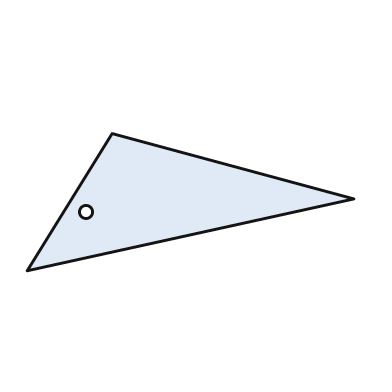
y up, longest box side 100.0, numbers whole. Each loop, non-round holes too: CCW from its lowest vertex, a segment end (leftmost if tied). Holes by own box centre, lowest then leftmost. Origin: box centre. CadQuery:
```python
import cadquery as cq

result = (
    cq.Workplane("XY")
    .moveTo(-50.0, -21.0)
    .lineTo(50.0, 1.0)
    .lineTo(-24.0, 21.0)
    .close()
    .moveTo(-32.0, -3.0)
    .circle(2.0)
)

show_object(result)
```